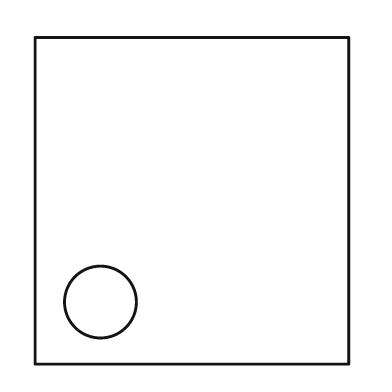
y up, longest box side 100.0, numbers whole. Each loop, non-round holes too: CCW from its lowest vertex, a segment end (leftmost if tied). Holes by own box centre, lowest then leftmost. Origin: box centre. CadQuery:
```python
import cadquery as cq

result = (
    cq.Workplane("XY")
    .moveTo(-48.0, -50.0)
    .lineTo(48.0, -50.0)
    .lineTo(48.0, 50.0)
    .lineTo(-48.0, 50.0)
    .close()
    .moveTo(-28.0, -31.0)
    .circle(11.0)
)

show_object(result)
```